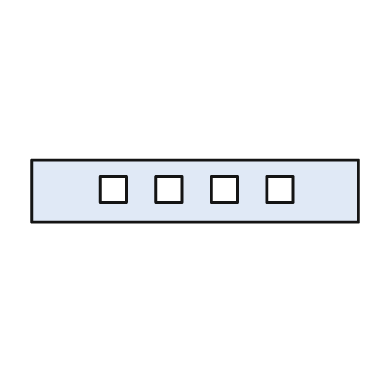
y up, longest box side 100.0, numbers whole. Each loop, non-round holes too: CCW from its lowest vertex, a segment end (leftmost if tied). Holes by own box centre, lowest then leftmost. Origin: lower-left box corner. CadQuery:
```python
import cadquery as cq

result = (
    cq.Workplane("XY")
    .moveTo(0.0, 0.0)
    .lineTo(100.0, 0.0)
    .lineTo(100.0, 19.0)
    .lineTo(0.0, 19.0)
    .close()
    .moveTo(21.0, 6.0)
    .lineTo(29.0, 6.0)
    .lineTo(29.0, 14.0)
    .lineTo(21.0, 14.0)
    .close()
    .moveTo(38.0, 6.0)
    .lineTo(46.0, 6.0)
    .lineTo(46.0, 14.0)
    .lineTo(38.0, 14.0)
    .close()
    .moveTo(55.0, 6.0)
    .lineTo(63.0, 6.0)
    .lineTo(63.0, 14.0)
    .lineTo(55.0, 14.0)
    .close()
    .moveTo(72.0, 6.0)
    .lineTo(80.0, 6.0)
    .lineTo(80.0, 14.0)
    .lineTo(72.0, 14.0)
    .close()
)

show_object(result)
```